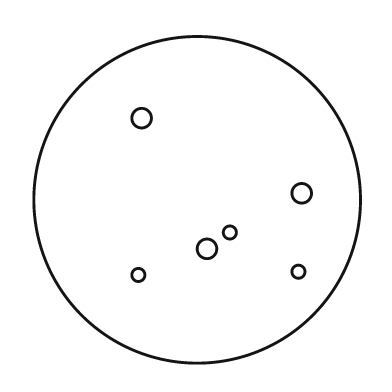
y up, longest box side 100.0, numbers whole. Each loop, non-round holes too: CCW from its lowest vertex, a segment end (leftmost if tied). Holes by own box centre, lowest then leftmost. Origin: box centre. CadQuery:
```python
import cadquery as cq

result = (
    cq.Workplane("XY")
    .moveTo(0.0, 0.0)
    .circle(50.0)
    .moveTo(-18.0, -23.0)
    .circle(2.0)
    .moveTo(31.0, -22.0)
    .circle(2.0)
    .moveTo(3.0, -15.0)
    .circle(3.0)
    .moveTo(10.0, -10.0)
    .circle(2.0)
    .moveTo(32.0, 2.0)
    .circle(3.0)
    .moveTo(-17.0, 25.0)
    .circle(3.0)
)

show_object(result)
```